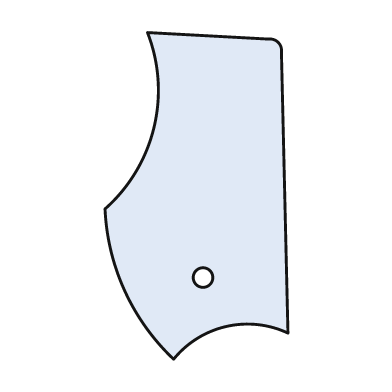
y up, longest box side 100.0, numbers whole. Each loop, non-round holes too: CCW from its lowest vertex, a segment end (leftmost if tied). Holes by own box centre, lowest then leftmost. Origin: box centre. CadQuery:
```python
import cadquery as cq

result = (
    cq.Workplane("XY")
    .moveTo(-7.0, -50.0)
    .threePointArc((9.0, -40.0), (28.0, -42.0))
    .lineTo(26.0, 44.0)
    .threePointArc((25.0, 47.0), (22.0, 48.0))
    .lineTo(-15.0, 50.0)
    .threePointArc((-13.0, 21.0), (-28.0, -4.0))
    .threePointArc((-22.0, -29.0), (-7.0, -50.0))
    .close()
    .moveTo(2.0, -25.0)
    .circle(3.0)
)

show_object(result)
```